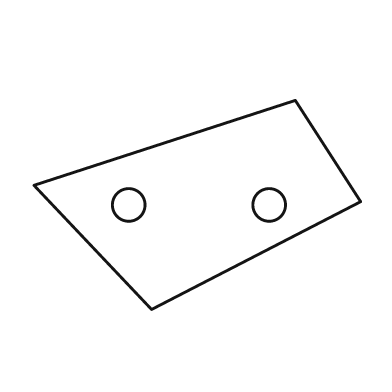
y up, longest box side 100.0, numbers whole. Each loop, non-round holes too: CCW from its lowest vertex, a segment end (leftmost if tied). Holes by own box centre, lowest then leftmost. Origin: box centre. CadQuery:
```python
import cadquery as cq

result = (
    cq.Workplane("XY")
    .moveTo(-14.0, -32.0)
    .lineTo(50.0, 1.0)
    .lineTo(30.0, 32.0)
    .lineTo(-50.0, 6.0)
    .close()
    .moveTo(-21.0, 0.0)
    .circle(5.0)
    .moveTo(22.0, 0.0)
    .circle(5.0)
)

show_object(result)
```